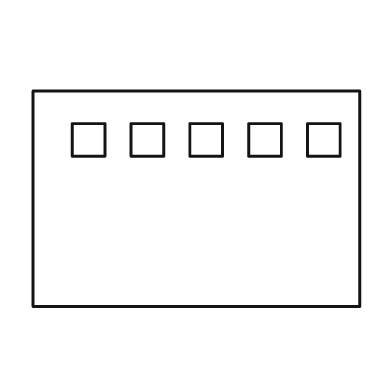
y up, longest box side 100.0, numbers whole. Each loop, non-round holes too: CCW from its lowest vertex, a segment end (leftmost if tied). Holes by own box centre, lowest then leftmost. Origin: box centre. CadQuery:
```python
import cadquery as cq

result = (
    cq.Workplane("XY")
    .moveTo(-50.0, -33.0)
    .lineTo(50.0, -33.0)
    .lineTo(50.0, 33.0)
    .lineTo(-50.0, 33.0)
    .close()
    .moveTo(-38.0, 13.0)
    .lineTo(-28.0, 13.0)
    .lineTo(-28.0, 23.0)
    .lineTo(-38.0, 23.0)
    .close()
    .moveTo(-20.0, 13.0)
    .lineTo(-10.0, 13.0)
    .lineTo(-10.0, 23.0)
    .lineTo(-20.0, 23.0)
    .close()
    .moveTo(-2.0, 13.0)
    .lineTo(8.0, 13.0)
    .lineTo(8.0, 23.0)
    .lineTo(-2.0, 23.0)
    .close()
    .moveTo(16.0, 13.0)
    .lineTo(26.0, 13.0)
    .lineTo(26.0, 23.0)
    .lineTo(16.0, 23.0)
    .close()
    .moveTo(34.0, 13.0)
    .lineTo(44.0, 13.0)
    .lineTo(44.0, 23.0)
    .lineTo(34.0, 23.0)
    .close()
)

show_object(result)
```